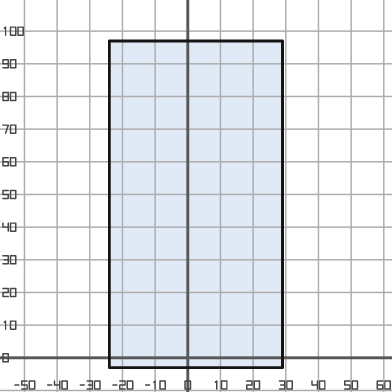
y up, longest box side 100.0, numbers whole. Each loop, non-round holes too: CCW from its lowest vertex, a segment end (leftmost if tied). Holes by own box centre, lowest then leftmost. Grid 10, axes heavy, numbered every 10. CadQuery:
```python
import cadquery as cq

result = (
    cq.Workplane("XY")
    .moveTo(-24.0, -3.0)
    .lineTo(29.0, -3.0)
    .lineTo(29.0, 97.0)
    .lineTo(-24.0, 97.0)
    .close()
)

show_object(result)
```